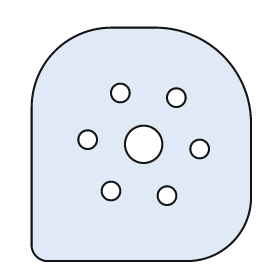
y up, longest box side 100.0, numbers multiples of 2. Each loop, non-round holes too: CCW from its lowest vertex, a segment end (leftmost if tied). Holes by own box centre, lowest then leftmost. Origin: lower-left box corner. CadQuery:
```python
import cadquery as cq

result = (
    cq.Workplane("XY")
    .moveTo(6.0, 0.0)
    .lineTo(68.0, 0.0)
    .threePointArc((86.0, 8.0), (94.0, 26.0))
    .lineTo(94.0, 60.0)
    .threePointArc((82.0, 88.0), (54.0, 100.0))
    .lineTo(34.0, 100.0)
    .threePointArc((10.0, 90.0), (0.0, 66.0))
    .lineTo(0.0, 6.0)
    .threePointArc((2.0, 2.0), (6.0, 0.0))
    .close()
    .moveTo(58.0, 28.0)
    .circle(4.0)
    .moveTo(34.0, 30.0)
    .circle(4.0)
    .moveTo(72.0, 48.0)
    .circle(4.0)
    .moveTo(48.0, 50.0)
    .circle(8.0)
    .moveTo(24.0, 52.0)
    .circle(4.0)
    .moveTo(62.0, 70.0)
    .circle(4.0)
    .moveTo(38.0, 72.0)
    .circle(4.0)
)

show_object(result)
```